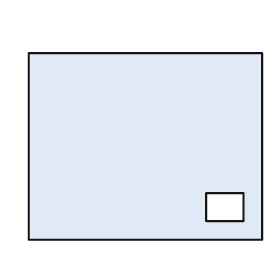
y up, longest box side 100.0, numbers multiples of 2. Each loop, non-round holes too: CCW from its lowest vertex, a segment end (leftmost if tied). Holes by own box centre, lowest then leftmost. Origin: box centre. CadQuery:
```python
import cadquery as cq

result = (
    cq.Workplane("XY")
    .moveTo(-50.0, -40.0)
    .lineTo(50.0, -40.0)
    .lineTo(50.0, 40.0)
    .lineTo(-50.0, 40.0)
    .close()
    .moveTo(26.0, -32.0)
    .lineTo(42.0, -32.0)
    .lineTo(42.0, -20.0)
    .lineTo(26.0, -20.0)
    .close()
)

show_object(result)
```